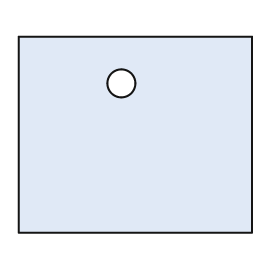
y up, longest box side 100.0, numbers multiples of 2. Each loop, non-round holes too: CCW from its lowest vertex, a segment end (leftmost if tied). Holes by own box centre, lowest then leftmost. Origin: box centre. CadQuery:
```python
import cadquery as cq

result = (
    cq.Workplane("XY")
    .moveTo(-50.0, -42.0)
    .lineTo(50.0, -42.0)
    .lineTo(50.0, 42.0)
    .lineTo(-50.0, 42.0)
    .close()
    .moveTo(-6.0, 22.0)
    .circle(6.0)
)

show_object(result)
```